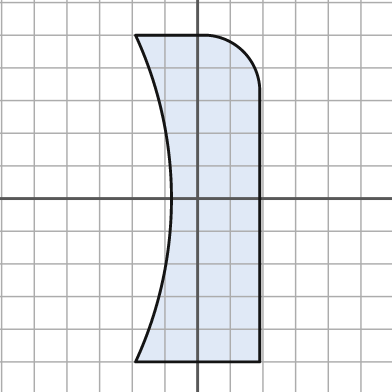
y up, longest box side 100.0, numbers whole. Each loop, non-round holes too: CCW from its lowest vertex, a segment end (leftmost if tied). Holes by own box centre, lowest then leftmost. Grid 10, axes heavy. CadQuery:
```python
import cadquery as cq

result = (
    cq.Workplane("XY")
    .moveTo(-19.0, -50.0)
    .lineTo(19.0, -50.0)
    .lineTo(19.0, 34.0)
    .threePointArc((14.0, 45.0), (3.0, 50.0))
    .lineTo(-19.0, 50.0)
    .threePointArc((-8.0, 0.0), (-19.0, -50.0))
    .close()
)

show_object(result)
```